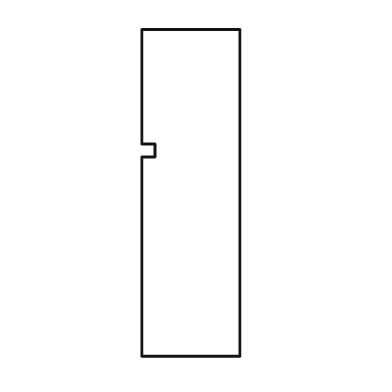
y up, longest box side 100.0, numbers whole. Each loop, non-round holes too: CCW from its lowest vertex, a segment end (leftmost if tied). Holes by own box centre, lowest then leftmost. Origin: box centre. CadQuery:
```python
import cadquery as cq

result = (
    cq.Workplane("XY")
    .moveTo(-15.0, -50.0)
    .lineTo(15.0, -50.0)
    .lineTo(15.0, 50.0)
    .lineTo(-15.0, 50.0)
    .lineTo(-15.0, 15.0)
    .lineTo(-11.0, 15.0)
    .lineTo(-11.0, 11.0)
    .lineTo(-15.0, 11.0)
    .close()
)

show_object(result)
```